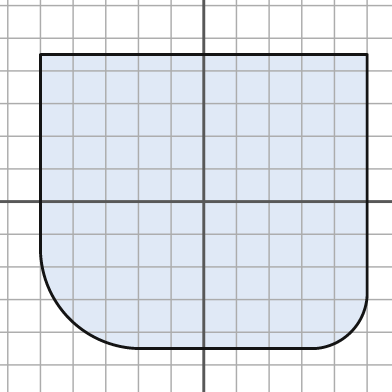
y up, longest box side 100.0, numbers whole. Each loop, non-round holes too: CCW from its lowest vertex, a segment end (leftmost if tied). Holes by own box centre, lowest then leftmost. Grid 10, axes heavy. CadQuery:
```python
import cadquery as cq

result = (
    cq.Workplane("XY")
    .moveTo(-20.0, -45.0)
    .lineTo(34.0, -45.0)
    .threePointArc((45.0, -40.0), (50.0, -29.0))
    .lineTo(50.0, 45.0)
    .lineTo(-50.0, 45.0)
    .lineTo(-50.0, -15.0)
    .threePointArc((-41.0, -36.0), (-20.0, -45.0))
    .close()
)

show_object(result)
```